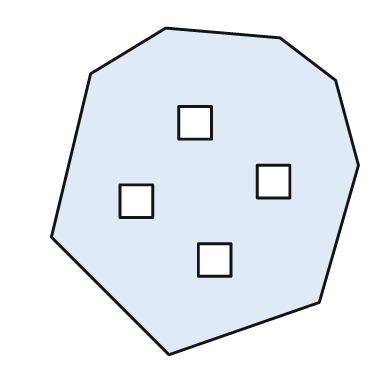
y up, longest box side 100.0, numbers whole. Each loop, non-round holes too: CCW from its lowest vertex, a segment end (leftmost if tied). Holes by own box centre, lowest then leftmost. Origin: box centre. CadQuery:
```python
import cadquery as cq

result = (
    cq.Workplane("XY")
    .moveTo(-11.0, -50.0)
    .lineTo(35.0, -34.0)
    .lineTo(47.0, 8.0)
    .lineTo(40.0, 34.0)
    .lineTo(23.0, 47.0)
    .lineTo(-12.0, 50.0)
    .lineTo(-35.0, 36.0)
    .lineTo(-47.0, -14.0)
    .close()
    .moveTo(-2.0, -26.0)
    .lineTo(8.0, -26.0)
    .lineTo(8.0, -16.0)
    .lineTo(-2.0, -16.0)
    .close()
    .moveTo(-26.0, -8.0)
    .lineTo(-16.0, -8.0)
    .lineTo(-16.0, 2.0)
    .lineTo(-26.0, 2.0)
    .close()
    .moveTo(16.0, -2.0)
    .lineTo(26.0, -2.0)
    .lineTo(26.0, 8.0)
    .lineTo(16.0, 8.0)
    .close()
    .moveTo(-8.0, 16.0)
    .lineTo(2.0, 16.0)
    .lineTo(2.0, 26.0)
    .lineTo(-8.0, 26.0)
    .close()
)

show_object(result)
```